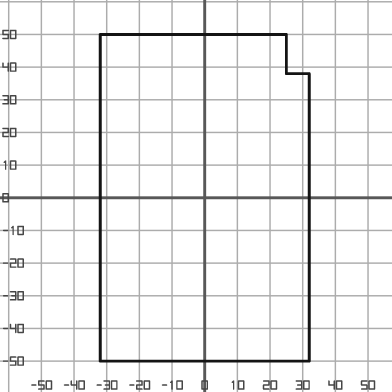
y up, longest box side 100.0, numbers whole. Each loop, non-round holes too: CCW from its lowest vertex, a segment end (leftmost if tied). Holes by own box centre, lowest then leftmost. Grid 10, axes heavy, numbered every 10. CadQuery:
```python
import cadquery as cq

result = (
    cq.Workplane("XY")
    .moveTo(-32.0, -50.0)
    .lineTo(32.0, -50.0)
    .lineTo(32.0, 38.0)
    .lineTo(25.0, 38.0)
    .lineTo(25.0, 50.0)
    .lineTo(-32.0, 50.0)
    .close()
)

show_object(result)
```